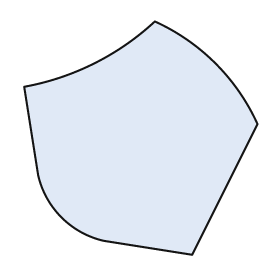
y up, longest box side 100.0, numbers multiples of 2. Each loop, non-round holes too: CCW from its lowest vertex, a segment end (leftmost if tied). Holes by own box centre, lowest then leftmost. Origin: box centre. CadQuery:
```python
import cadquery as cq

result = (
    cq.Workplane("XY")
    .moveTo(22.0, -50.0)
    .lineTo(50.0, 6.0)
    .threePointArc((32.0, 32.0), (6.0, 50.0))
    .threePointArc((-20.0, 32.0), (-50.0, 22.0))
    .lineTo(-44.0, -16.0)
    .threePointArc((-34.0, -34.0), (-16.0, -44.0))
    .close()
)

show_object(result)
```